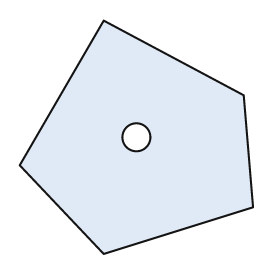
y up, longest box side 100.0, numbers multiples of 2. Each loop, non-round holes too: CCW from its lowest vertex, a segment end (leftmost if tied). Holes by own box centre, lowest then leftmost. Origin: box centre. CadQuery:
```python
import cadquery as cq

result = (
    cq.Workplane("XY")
    .moveTo(-14.0, -50.0)
    .lineTo(50.0, -30.0)
    .lineTo(46.0, 18.0)
    .lineTo(-14.0, 50.0)
    .lineTo(-50.0, -12.0)
    .close()
    .moveTo(0.0, 0.0)
    .circle(6.0)
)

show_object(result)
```